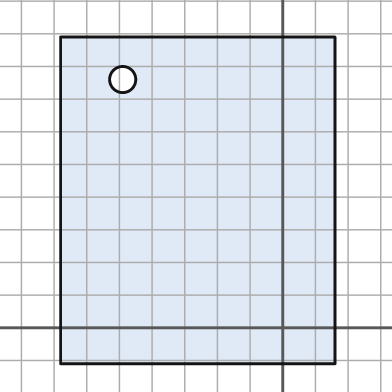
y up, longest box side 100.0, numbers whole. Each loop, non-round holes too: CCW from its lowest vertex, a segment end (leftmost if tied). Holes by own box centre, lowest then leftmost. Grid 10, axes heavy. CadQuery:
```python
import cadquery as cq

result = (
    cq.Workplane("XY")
    .moveTo(-68.0, -11.0)
    .lineTo(16.0, -11.0)
    .lineTo(16.0, 89.0)
    .lineTo(-68.0, 89.0)
    .close()
    .moveTo(-49.0, 76.0)
    .circle(4.0)
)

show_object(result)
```